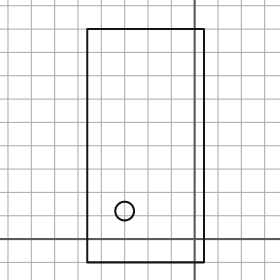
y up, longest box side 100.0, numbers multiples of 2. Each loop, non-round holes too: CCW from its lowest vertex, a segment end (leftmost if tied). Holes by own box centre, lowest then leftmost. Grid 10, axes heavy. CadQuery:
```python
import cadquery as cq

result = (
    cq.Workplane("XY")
    .moveTo(-46.0, -10.0)
    .lineTo(4.0, -10.0)
    .lineTo(4.0, 90.0)
    .lineTo(-46.0, 90.0)
    .close()
    .moveTo(-30.0, 12.0)
    .circle(4.0)
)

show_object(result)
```